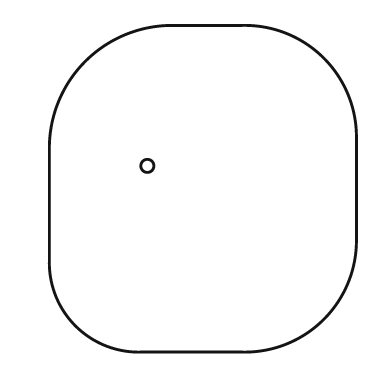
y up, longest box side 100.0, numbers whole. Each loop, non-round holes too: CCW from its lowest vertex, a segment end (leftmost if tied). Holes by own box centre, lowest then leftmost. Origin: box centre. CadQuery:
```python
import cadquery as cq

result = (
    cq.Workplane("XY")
    .moveTo(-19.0, -50.0)
    .lineTo(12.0, -50.0)
    .threePointArc((37.0, -40.0), (47.0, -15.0))
    .lineTo(47.0, 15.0)
    .threePointArc((37.0, 40.0), (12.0, 50.0))
    .lineTo(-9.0, 50.0)
    .threePointArc((-36.0, 39.0), (-47.0, 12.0))
    .lineTo(-47.0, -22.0)
    .threePointArc((-39.0, -42.0), (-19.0, -50.0))
    .close()
    .moveTo(-17.0, 7.0)
    .circle(2.0)
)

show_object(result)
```